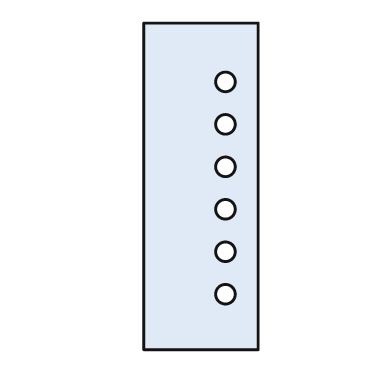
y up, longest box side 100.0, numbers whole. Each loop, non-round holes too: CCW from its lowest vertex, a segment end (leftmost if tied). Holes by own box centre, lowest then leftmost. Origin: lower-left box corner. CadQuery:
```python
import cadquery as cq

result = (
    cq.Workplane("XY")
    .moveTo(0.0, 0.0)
    .lineTo(35.0, 0.0)
    .lineTo(35.0, 100.0)
    .lineTo(0.0, 100.0)
    .close()
    .moveTo(25.0, 17.0)
    .circle(3.0)
    .moveTo(25.0, 30.0)
    .circle(3.0)
    .moveTo(25.0, 43.0)
    .circle(3.0)
    .moveTo(25.0, 56.0)
    .circle(3.0)
    .moveTo(25.0, 69.0)
    .circle(3.0)
    .moveTo(25.0, 82.0)
    .circle(3.0)
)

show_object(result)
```